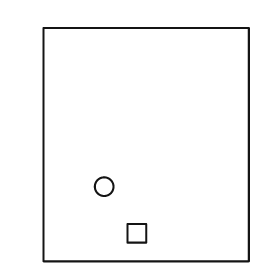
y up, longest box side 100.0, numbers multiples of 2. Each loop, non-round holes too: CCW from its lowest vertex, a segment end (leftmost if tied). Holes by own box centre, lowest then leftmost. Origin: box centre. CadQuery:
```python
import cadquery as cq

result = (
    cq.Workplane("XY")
    .moveTo(-44.0, -50.0)
    .lineTo(44.0, -50.0)
    .lineTo(44.0, 50.0)
    .lineTo(-44.0, 50.0)
    .close()
    .moveTo(-8.0, -42.0)
    .lineTo(0.0, -42.0)
    .lineTo(0.0, -34.0)
    .lineTo(-8.0, -34.0)
    .close()
    .moveTo(-18.0, -18.0)
    .circle(4.0)
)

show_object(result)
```